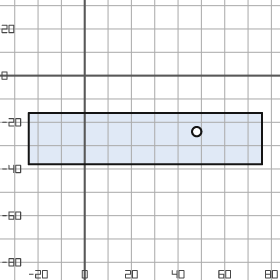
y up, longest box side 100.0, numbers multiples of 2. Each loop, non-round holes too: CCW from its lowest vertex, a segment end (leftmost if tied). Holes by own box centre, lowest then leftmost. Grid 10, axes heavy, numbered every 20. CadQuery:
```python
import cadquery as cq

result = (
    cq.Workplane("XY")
    .moveTo(-24.0, -38.0)
    .lineTo(76.0, -38.0)
    .lineTo(76.0, -16.0)
    .lineTo(-24.0, -16.0)
    .close()
    .moveTo(48.0, -24.0)
    .circle(2.0)
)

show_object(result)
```